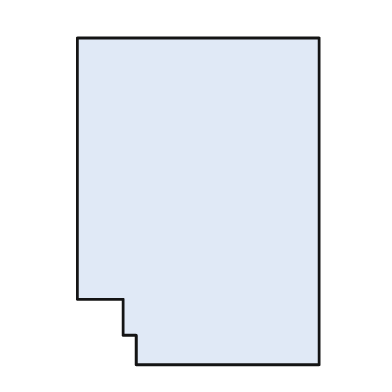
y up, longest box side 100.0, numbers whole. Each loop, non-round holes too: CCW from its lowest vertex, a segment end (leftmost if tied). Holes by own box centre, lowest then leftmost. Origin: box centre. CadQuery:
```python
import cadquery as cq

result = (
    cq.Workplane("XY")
    .moveTo(-19.0, -50.0)
    .lineTo(37.0, -50.0)
    .lineTo(37.0, 50.0)
    .lineTo(-37.0, 50.0)
    .lineTo(-37.0, -30.0)
    .lineTo(-23.0, -30.0)
    .lineTo(-23.0, -41.0)
    .lineTo(-19.0, -41.0)
    .close()
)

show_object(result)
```